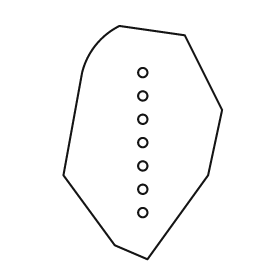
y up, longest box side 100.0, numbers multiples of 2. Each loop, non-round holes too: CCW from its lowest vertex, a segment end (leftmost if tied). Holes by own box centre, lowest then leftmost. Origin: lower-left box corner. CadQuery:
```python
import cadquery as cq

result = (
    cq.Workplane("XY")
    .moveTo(36.0, 0.0)
    .lineTo(62.0, 36.0)
    .lineTo(68.0, 64.0)
    .lineTo(52.0, 96.0)
    .lineTo(24.0, 100.0)
    .threePointArc((14.0, 92.0), (8.0, 80.0))
    .lineTo(0.0, 36.0)
    .lineTo(22.0, 6.0)
    .close()
    .moveTo(34.0, 20.0)
    .circle(2.0)
    .moveTo(34.0, 30.0)
    .circle(2.0)
    .moveTo(34.0, 40.0)
    .circle(2.0)
    .moveTo(34.0, 50.0)
    .circle(2.0)
    .moveTo(34.0, 60.0)
    .circle(2.0)
    .moveTo(34.0, 70.0)
    .circle(2.0)
    .moveTo(34.0, 80.0)
    .circle(2.0)
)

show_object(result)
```